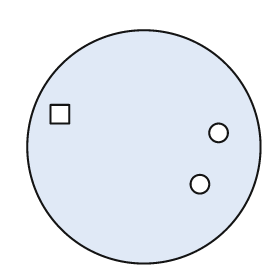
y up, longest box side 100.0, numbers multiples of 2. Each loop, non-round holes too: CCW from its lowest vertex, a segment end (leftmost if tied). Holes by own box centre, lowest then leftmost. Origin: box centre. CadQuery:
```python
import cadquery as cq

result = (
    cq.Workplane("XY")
    .moveTo(0.0, 0.0)
    .circle(50.0)
    .moveTo(24.0, -16.0)
    .circle(4.0)
    .moveTo(32.0, 6.0)
    .circle(4.0)
    .moveTo(-40.0, 10.0)
    .lineTo(-32.0, 10.0)
    .lineTo(-32.0, 18.0)
    .lineTo(-40.0, 18.0)
    .close()
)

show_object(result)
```